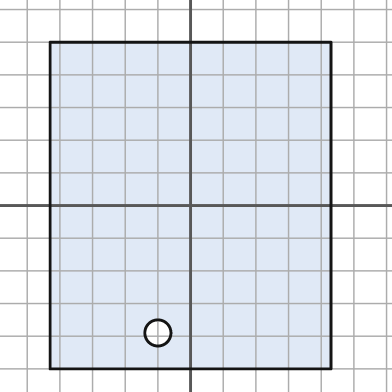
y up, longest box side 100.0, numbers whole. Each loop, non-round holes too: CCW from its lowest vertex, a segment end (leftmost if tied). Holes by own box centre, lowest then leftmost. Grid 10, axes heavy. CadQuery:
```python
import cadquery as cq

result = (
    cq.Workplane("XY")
    .moveTo(-43.0, -50.0)
    .lineTo(43.0, -50.0)
    .lineTo(43.0, 50.0)
    .lineTo(-43.0, 50.0)
    .close()
    .moveTo(-10.0, -39.0)
    .circle(4.0)
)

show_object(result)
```